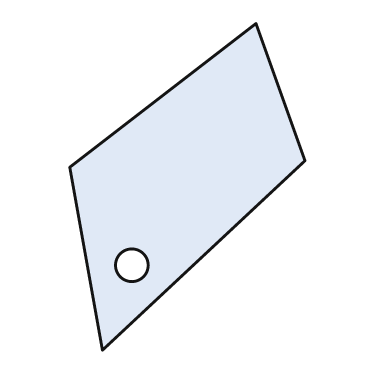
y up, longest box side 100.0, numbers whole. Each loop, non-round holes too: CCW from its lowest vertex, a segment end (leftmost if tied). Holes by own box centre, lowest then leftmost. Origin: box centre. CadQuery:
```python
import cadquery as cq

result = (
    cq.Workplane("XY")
    .moveTo(-26.0, -50.0)
    .lineTo(36.0, 8.0)
    .lineTo(21.0, 50.0)
    .lineTo(-36.0, 6.0)
    .close()
    .moveTo(-17.0, -24.0)
    .circle(5.0)
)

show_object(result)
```